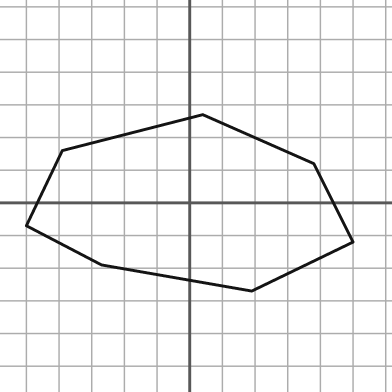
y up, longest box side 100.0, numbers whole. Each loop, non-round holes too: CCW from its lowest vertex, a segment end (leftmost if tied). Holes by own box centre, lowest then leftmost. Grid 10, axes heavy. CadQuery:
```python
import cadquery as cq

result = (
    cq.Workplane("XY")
    .moveTo(19.0, -27.0)
    .lineTo(50.0, -12.0)
    .lineTo(38.0, 12.0)
    .lineTo(4.0, 27.0)
    .lineTo(-39.0, 16.0)
    .lineTo(-50.0, -7.0)
    .lineTo(-27.0, -19.0)
    .close()
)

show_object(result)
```